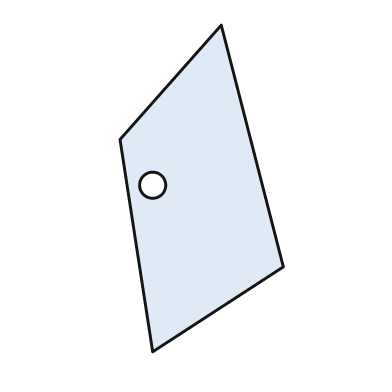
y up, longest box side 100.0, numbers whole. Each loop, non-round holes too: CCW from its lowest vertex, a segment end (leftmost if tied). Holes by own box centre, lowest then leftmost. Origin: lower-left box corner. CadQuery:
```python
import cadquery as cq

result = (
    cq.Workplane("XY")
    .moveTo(10.0, 0.0)
    .lineTo(50.0, 26.0)
    .lineTo(31.0, 100.0)
    .lineTo(0.0, 65.0)
    .close()
    .moveTo(10.0, 51.0)
    .circle(4.0)
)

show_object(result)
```